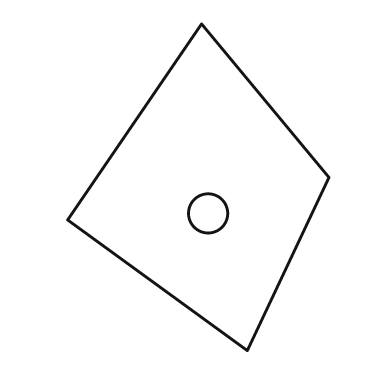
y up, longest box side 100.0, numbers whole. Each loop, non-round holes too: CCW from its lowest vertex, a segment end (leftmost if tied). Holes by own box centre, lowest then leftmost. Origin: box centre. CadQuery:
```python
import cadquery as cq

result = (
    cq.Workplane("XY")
    .moveTo(15.0, -50.0)
    .lineTo(40.0, 3.0)
    .lineTo(1.0, 50.0)
    .lineTo(-40.0, -10.0)
    .close()
    .moveTo(3.0, -8.0)
    .circle(6.0)
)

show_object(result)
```